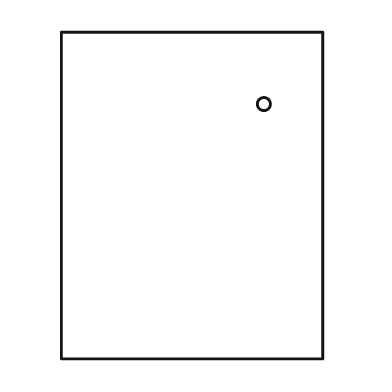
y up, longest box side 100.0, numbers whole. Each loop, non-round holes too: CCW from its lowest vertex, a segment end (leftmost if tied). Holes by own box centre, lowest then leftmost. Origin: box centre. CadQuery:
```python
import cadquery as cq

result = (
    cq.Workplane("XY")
    .moveTo(-40.0, -50.0)
    .lineTo(40.0, -50.0)
    .lineTo(40.0, 50.0)
    .lineTo(-40.0, 50.0)
    .close()
    .moveTo(22.0, 28.0)
    .circle(2.0)
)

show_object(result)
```